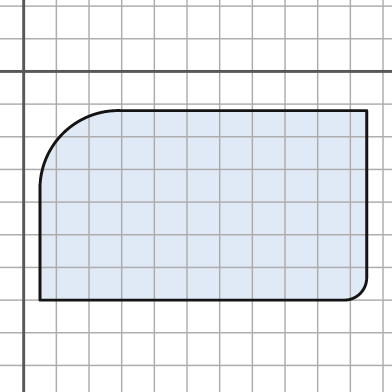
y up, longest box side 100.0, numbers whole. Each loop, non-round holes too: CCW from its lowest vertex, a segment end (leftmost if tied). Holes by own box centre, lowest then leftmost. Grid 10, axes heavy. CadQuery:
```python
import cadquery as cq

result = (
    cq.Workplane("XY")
    .moveTo(5.0, -70.0)
    .lineTo(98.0, -70.0)
    .threePointArc((103.0, -68.0), (105.0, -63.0))
    .lineTo(105.0, -12.0)
    .lineTo(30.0, -12.0)
    .threePointArc((12.0, -19.0), (5.0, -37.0))
    .close()
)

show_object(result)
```